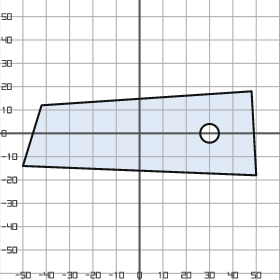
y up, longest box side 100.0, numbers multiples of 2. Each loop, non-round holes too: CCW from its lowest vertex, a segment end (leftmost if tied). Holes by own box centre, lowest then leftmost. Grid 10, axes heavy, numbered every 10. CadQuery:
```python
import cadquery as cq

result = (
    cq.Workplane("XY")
    .moveTo(50.0, -18.0)
    .lineTo(48.0, 18.0)
    .lineTo(-42.0, 12.0)
    .lineTo(-50.0, -14.0)
    .close()
    .moveTo(30.0, 0.0)
    .circle(4.0)
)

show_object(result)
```